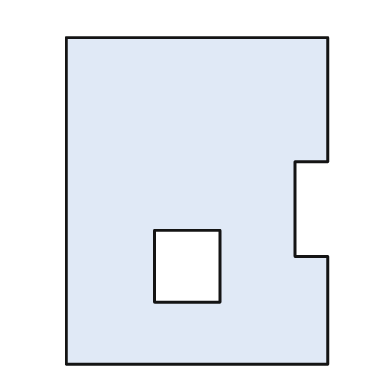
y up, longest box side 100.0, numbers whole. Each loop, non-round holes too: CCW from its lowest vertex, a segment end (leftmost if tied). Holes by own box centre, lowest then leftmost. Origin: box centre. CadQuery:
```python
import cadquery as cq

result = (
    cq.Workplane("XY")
    .moveTo(-40.0, -50.0)
    .lineTo(40.0, -50.0)
    .lineTo(40.0, -17.0)
    .lineTo(30.0, -17.0)
    .lineTo(30.0, 12.0)
    .lineTo(40.0, 12.0)
    .lineTo(40.0, 50.0)
    .lineTo(-40.0, 50.0)
    .close()
    .moveTo(-13.0, -31.0)
    .lineTo(7.0, -31.0)
    .lineTo(7.0, -9.0)
    .lineTo(-13.0, -9.0)
    .close()
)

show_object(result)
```